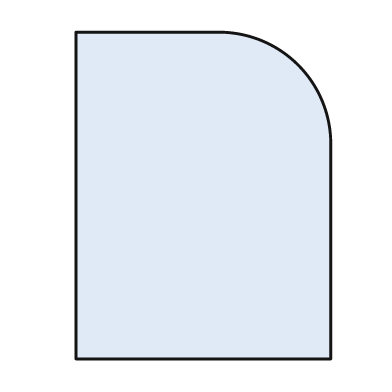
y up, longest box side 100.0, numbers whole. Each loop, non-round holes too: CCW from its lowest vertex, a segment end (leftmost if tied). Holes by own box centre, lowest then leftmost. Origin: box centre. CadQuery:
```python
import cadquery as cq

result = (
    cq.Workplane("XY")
    .moveTo(-39.0, -50.0)
    .lineTo(39.0, -50.0)
    .lineTo(39.0, 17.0)
    .threePointArc((29.0, 40.0), (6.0, 50.0))
    .lineTo(-39.0, 50.0)
    .close()
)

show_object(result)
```